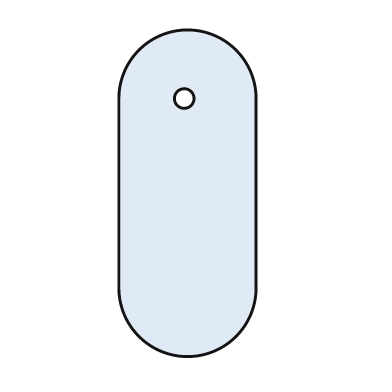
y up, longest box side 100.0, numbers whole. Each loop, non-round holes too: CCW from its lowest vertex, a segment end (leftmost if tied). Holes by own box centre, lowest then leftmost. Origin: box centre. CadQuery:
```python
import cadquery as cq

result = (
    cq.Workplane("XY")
    .moveTo(-21.0, -29.0)
    .threePointArc((0.0, -50.0), (21.0, -29.0))
    .lineTo(21.0, 29.0)
    .threePointArc((0.0, 50.0), (-21.0, 29.0))
    .close()
    .moveTo(-1.0, 29.0)
    .circle(3.0)
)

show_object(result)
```